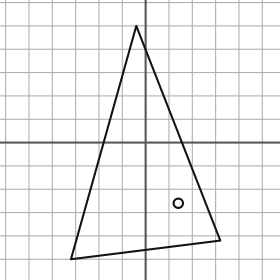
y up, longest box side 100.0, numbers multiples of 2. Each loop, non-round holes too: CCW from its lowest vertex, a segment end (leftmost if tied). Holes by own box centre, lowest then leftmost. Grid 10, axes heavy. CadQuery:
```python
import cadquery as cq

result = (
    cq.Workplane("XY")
    .moveTo(-32.0, -50.0)
    .lineTo(32.0, -42.0)
    .lineTo(-4.0, 50.0)
    .close()
    .moveTo(14.0, -26.0)
    .circle(2.0)
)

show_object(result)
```